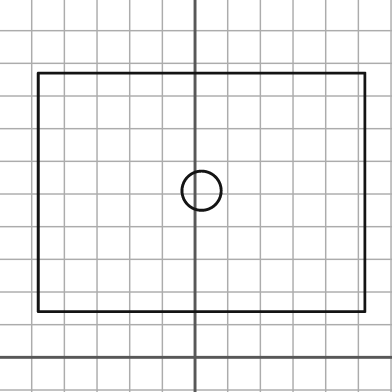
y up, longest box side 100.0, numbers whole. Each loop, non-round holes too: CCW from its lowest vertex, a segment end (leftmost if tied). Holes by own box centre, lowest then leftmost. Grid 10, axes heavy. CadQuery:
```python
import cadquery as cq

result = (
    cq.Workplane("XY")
    .moveTo(-48.0, 14.0)
    .lineTo(52.0, 14.0)
    .lineTo(52.0, 87.0)
    .lineTo(-48.0, 87.0)
    .close()
    .moveTo(2.0, 51.0)
    .circle(6.0)
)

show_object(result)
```